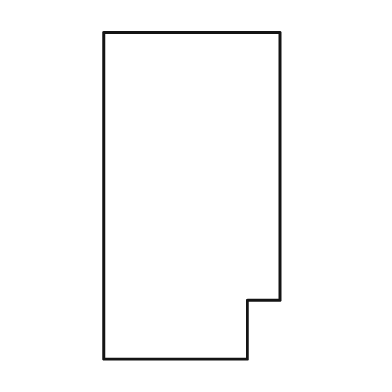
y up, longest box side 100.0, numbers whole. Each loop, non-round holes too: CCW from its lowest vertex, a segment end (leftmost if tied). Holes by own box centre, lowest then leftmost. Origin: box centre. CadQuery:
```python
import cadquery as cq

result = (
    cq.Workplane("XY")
    .moveTo(-27.0, -50.0)
    .lineTo(17.0, -50.0)
    .lineTo(17.0, -32.0)
    .lineTo(27.0, -32.0)
    .lineTo(27.0, 50.0)
    .lineTo(-27.0, 50.0)
    .close()
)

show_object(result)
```